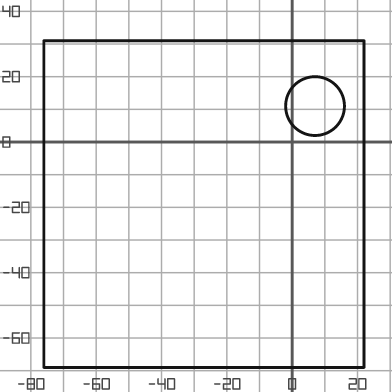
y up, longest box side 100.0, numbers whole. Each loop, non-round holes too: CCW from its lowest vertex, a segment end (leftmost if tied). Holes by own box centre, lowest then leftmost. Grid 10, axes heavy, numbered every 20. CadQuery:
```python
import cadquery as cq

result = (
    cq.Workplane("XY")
    .moveTo(-76.0, -69.0)
    .lineTo(22.0, -69.0)
    .lineTo(22.0, 31.0)
    .lineTo(-76.0, 31.0)
    .close()
    .moveTo(7.0, 11.0)
    .circle(9.0)
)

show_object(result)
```